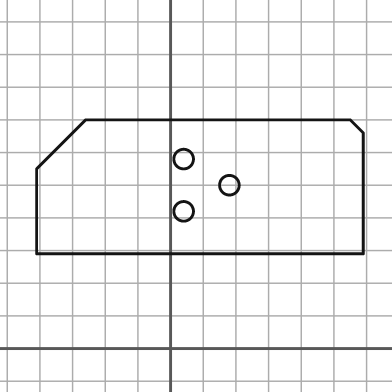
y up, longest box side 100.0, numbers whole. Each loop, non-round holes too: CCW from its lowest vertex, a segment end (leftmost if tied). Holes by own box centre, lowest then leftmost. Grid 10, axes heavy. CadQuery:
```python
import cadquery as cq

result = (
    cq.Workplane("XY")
    .moveTo(-41.0, 29.0)
    .lineTo(59.0, 29.0)
    .lineTo(59.0, 66.0)
    .lineTo(55.0, 70.0)
    .lineTo(-26.0, 70.0)
    .lineTo(-41.0, 55.0)
    .close()
    .moveTo(4.0, 42.0)
    .circle(3.0)
    .moveTo(18.0, 50.0)
    .circle(3.0)
    .moveTo(4.0, 58.0)
    .circle(3.0)
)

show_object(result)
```